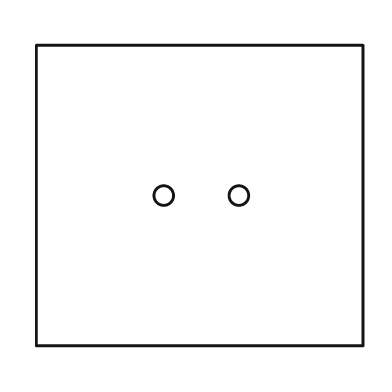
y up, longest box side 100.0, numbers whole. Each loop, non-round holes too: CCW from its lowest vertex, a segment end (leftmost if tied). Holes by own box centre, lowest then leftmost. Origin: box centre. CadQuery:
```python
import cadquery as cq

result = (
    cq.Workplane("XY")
    .moveTo(-50.0, -46.0)
    .lineTo(50.0, -46.0)
    .lineTo(50.0, 46.0)
    .lineTo(-50.0, 46.0)
    .close()
    .moveTo(-11.0, 0.0)
    .circle(3.0)
    .moveTo(12.0, 0.0)
    .circle(3.0)
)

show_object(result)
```